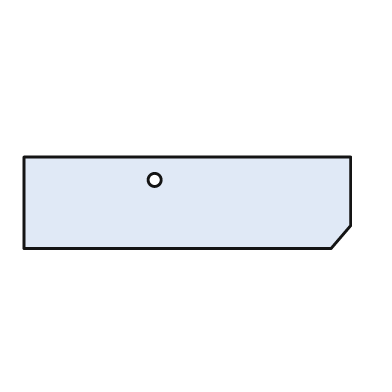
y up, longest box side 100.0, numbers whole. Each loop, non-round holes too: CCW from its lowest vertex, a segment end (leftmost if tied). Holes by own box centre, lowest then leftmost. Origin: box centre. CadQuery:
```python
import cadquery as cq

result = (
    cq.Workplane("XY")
    .moveTo(-50.0, -14.0)
    .lineTo(44.0, -14.0)
    .lineTo(50.0, -7.0)
    .lineTo(50.0, 14.0)
    .lineTo(-50.0, 14.0)
    .close()
    .moveTo(-10.0, 7.0)
    .circle(2.0)
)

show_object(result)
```